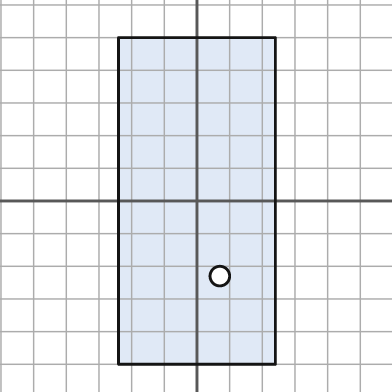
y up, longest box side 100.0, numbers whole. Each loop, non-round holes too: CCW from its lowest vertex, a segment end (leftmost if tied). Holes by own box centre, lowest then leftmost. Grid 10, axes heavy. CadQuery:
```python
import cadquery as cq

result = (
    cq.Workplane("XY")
    .moveTo(-24.0, -50.0)
    .lineTo(24.0, -50.0)
    .lineTo(24.0, 50.0)
    .lineTo(-24.0, 50.0)
    .close()
    .moveTo(7.0, -23.0)
    .circle(3.0)
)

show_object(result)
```